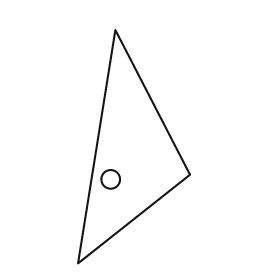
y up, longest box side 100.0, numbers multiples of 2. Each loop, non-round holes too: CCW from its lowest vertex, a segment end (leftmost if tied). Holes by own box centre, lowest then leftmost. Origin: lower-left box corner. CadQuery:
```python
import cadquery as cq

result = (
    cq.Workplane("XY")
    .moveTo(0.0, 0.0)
    .lineTo(48.0, 38.0)
    .lineTo(16.0, 100.0)
    .close()
    .moveTo(14.0, 36.0)
    .circle(4.0)
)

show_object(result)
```